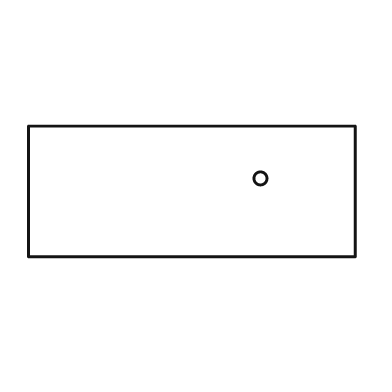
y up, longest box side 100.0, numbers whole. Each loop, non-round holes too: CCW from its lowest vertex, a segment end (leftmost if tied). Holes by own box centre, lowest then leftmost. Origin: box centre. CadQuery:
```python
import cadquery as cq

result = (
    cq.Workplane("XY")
    .moveTo(-50.0, -20.0)
    .lineTo(50.0, -20.0)
    .lineTo(50.0, 20.0)
    .lineTo(-50.0, 20.0)
    .close()
    .moveTo(21.0, 4.0)
    .circle(2.0)
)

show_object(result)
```